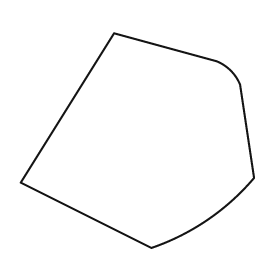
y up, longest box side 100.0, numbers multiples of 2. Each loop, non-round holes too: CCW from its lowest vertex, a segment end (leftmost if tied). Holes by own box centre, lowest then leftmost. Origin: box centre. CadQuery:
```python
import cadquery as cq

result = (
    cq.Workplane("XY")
    .moveTo(6.0, -46.0)
    .threePointArc((30.0, -34.0), (50.0, -16.0))
    .lineTo(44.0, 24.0)
    .threePointArc((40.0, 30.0), (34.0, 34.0))
    .lineTo(-10.0, 46.0)
    .lineTo(-50.0, -18.0)
    .close()
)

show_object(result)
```